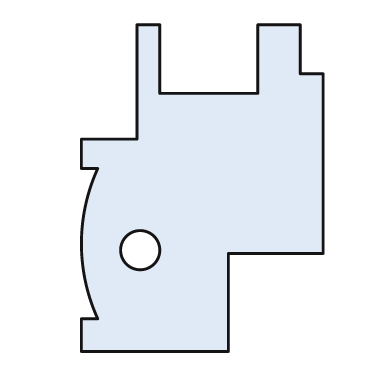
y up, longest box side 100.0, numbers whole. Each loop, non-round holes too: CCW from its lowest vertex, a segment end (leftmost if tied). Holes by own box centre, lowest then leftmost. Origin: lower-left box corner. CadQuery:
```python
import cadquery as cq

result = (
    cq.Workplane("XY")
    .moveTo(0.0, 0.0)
    .lineTo(45.0, 0.0)
    .lineTo(45.0, 30.0)
    .lineTo(74.0, 30.0)
    .lineTo(74.0, 85.0)
    .lineTo(67.0, 85.0)
    .lineTo(67.0, 100.0)
    .lineTo(54.0, 100.0)
    .lineTo(54.0, 79.0)
    .lineTo(24.0, 79.0)
    .lineTo(24.0, 100.0)
    .lineTo(17.0, 100.0)
    .lineTo(17.0, 65.0)
    .lineTo(0.0, 65.0)
    .lineTo(0.0, 56.0)
    .lineTo(5.0, 56.0)
    .threePointArc((0.0, 33.0), (5.0, 10.0))
    .lineTo(0.0, 10.0)
    .close()
    .moveTo(18.0, 31.0)
    .circle(6.0)
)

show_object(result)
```